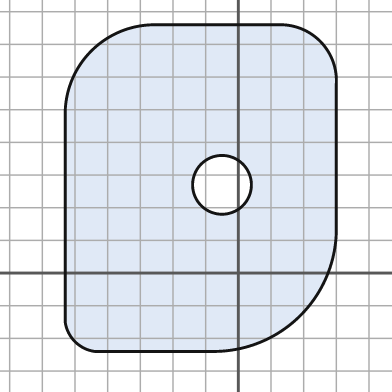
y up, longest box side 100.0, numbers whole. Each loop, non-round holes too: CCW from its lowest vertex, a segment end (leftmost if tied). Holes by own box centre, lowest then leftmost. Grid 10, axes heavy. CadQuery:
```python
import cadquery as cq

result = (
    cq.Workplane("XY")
    .moveTo(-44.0, -24.0)
    .lineTo(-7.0, -24.0)
    .threePointArc((19.0, -13.0), (30.0, 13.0))
    .lineTo(30.0, 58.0)
    .threePointArc((25.0, 71.0), (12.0, 76.0))
    .lineTo(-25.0, 76.0)
    .threePointArc((-45.0, 68.0), (-53.0, 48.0))
    .lineTo(-53.0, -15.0)
    .threePointArc((-50.0, -21.0), (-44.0, -24.0))
    .close()
    .moveTo(-5.0, 27.0)
    .circle(9.0)
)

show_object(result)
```